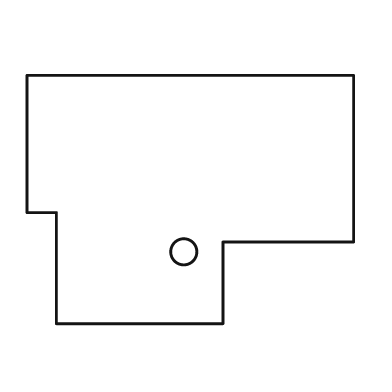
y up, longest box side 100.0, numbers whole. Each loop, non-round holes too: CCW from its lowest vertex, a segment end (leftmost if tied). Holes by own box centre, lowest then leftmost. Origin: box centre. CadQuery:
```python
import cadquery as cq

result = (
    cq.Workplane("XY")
    .moveTo(-41.0, -38.0)
    .lineTo(10.0, -38.0)
    .lineTo(10.0, -13.0)
    .lineTo(50.0, -13.0)
    .lineTo(50.0, 38.0)
    .lineTo(-50.0, 38.0)
    .lineTo(-50.0, -4.0)
    .lineTo(-41.0, -4.0)
    .close()
    .moveTo(-2.0, -16.0)
    .circle(4.0)
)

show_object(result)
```